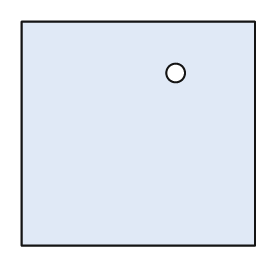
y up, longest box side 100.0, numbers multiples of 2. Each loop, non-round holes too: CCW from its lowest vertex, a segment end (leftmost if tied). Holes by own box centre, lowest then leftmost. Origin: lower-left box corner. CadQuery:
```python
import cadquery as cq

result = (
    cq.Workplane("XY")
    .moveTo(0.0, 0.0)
    .lineTo(100.0, 0.0)
    .lineTo(100.0, 96.0)
    .lineTo(0.0, 96.0)
    .close()
    .moveTo(66.0, 74.0)
    .circle(4.0)
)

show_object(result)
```